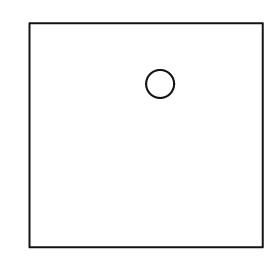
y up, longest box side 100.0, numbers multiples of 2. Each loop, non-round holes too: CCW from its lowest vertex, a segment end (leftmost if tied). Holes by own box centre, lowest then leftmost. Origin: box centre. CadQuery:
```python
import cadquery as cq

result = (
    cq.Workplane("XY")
    .moveTo(-50.0, -48.0)
    .lineTo(50.0, -48.0)
    .lineTo(50.0, 48.0)
    .lineTo(-50.0, 48.0)
    .close()
    .moveTo(6.0, 22.0)
    .circle(6.0)
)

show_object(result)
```